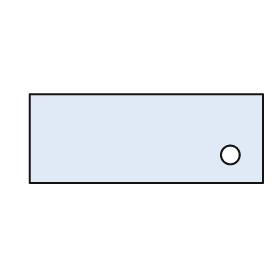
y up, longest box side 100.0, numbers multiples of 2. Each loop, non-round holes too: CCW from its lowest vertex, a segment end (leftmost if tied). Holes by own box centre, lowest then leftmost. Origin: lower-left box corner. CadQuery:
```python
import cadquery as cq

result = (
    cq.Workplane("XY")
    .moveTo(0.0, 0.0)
    .lineTo(100.0, 0.0)
    .lineTo(100.0, 38.0)
    .lineTo(0.0, 38.0)
    .close()
    .moveTo(86.0, 12.0)
    .circle(4.0)
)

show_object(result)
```